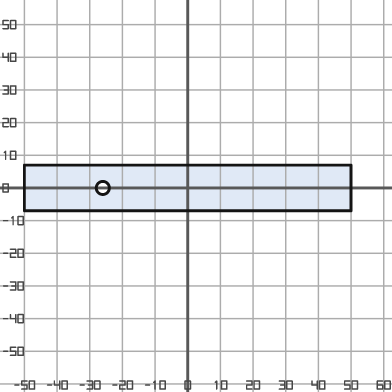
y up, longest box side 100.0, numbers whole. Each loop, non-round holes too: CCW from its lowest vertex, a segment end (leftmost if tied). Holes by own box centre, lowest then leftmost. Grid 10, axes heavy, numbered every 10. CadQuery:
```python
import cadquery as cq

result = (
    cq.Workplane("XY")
    .moveTo(-50.0, -7.0)
    .lineTo(50.0, -7.0)
    .lineTo(50.0, 7.0)
    .lineTo(-50.0, 7.0)
    .close()
    .moveTo(-26.0, 0.0)
    .circle(2.0)
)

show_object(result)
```